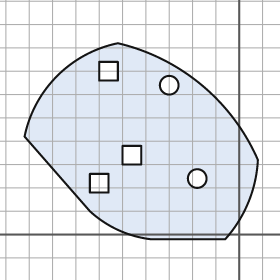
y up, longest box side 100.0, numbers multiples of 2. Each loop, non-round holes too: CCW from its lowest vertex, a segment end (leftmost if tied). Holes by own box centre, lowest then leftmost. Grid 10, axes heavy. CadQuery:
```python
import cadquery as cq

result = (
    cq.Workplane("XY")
    .moveTo(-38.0, -2.0)
    .lineTo(-6.0, -2.0)
    .threePointArc((4.0, 14.0), (8.0, 32.0))
    .threePointArc((-16.0, 64.0), (-52.0, 82.0))
    .threePointArc((-78.0, 68.0), (-92.0, 42.0))
    .lineTo(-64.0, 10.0)
    .threePointArc((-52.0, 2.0), (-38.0, -2.0))
    .close()
    .moveTo(-64.0, 18.0)
    .lineTo(-56.0, 18.0)
    .lineTo(-56.0, 26.0)
    .lineTo(-64.0, 26.0)
    .close()
    .moveTo(-18.0, 24.0)
    .circle(4.0)
    .moveTo(-50.0, 30.0)
    .lineTo(-42.0, 30.0)
    .lineTo(-42.0, 38.0)
    .lineTo(-50.0, 38.0)
    .close()
    .moveTo(-30.0, 64.0)
    .circle(4.0)
    .moveTo(-60.0, 66.0)
    .lineTo(-52.0, 66.0)
    .lineTo(-52.0, 74.0)
    .lineTo(-60.0, 74.0)
    .close()
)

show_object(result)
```